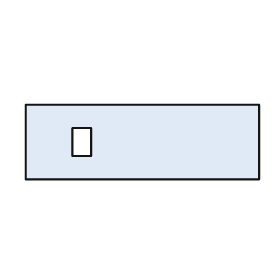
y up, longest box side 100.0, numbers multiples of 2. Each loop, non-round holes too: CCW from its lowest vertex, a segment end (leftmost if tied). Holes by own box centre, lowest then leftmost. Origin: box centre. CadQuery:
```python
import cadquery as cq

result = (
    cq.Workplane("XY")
    .moveTo(-50.0, -16.0)
    .lineTo(50.0, -16.0)
    .lineTo(50.0, 16.0)
    .lineTo(-50.0, 16.0)
    .close()
    .moveTo(-30.0, -6.0)
    .lineTo(-22.0, -6.0)
    .lineTo(-22.0, 6.0)
    .lineTo(-30.0, 6.0)
    .close()
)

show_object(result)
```